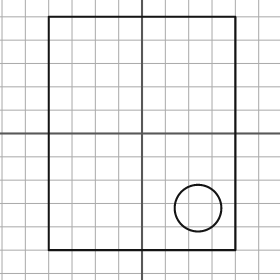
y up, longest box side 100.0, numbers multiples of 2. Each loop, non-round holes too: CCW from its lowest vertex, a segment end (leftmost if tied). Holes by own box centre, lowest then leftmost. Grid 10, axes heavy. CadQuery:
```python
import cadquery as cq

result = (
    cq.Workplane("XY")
    .moveTo(-40.0, -50.0)
    .lineTo(40.0, -50.0)
    .lineTo(40.0, 50.0)
    .lineTo(-40.0, 50.0)
    .close()
    .moveTo(24.0, -32.0)
    .circle(10.0)
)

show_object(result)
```